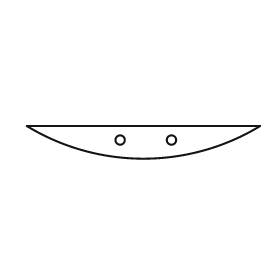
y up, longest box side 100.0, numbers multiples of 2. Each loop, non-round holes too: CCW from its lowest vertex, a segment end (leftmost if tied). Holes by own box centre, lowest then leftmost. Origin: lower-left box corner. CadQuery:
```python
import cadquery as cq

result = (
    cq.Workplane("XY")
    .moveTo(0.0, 14.0)
    .threePointArc((50.0, 0.0), (100.0, 14.0))
    .close()
    .moveTo(40.0, 8.0)
    .circle(2.0)
    .moveTo(62.0, 8.0)
    .circle(2.0)
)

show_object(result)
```